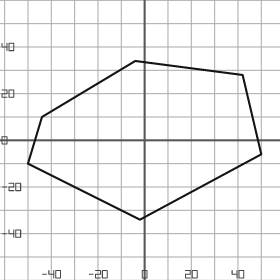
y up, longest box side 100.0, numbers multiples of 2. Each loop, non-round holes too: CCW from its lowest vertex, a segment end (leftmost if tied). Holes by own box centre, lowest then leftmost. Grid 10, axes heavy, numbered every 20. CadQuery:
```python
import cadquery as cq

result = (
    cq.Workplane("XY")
    .moveTo(-2.0, -34.0)
    .lineTo(50.0, -6.0)
    .lineTo(42.0, 28.0)
    .lineTo(-4.0, 34.0)
    .lineTo(-44.0, 10.0)
    .lineTo(-50.0, -10.0)
    .close()
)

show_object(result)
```